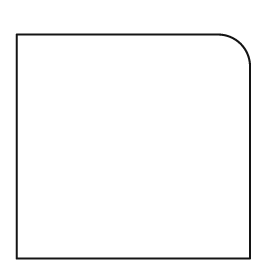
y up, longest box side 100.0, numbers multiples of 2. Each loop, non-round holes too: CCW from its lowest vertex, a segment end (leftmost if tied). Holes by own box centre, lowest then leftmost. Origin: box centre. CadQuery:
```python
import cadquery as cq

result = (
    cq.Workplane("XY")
    .moveTo(-50.0, -48.0)
    .lineTo(50.0, -48.0)
    .lineTo(50.0, 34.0)
    .threePointArc((46.0, 44.0), (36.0, 48.0))
    .lineTo(-50.0, 48.0)
    .close()
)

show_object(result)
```